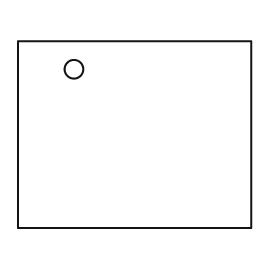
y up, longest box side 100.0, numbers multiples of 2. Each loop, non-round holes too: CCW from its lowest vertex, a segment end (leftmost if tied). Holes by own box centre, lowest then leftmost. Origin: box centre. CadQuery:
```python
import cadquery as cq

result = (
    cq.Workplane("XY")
    .moveTo(-50.0, -40.0)
    .lineTo(50.0, -40.0)
    .lineTo(50.0, 40.0)
    .lineTo(-50.0, 40.0)
    .close()
    .moveTo(-26.0, 28.0)
    .circle(4.0)
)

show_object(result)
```